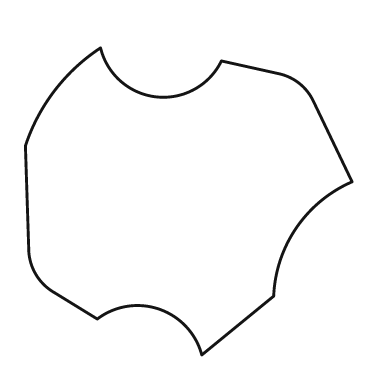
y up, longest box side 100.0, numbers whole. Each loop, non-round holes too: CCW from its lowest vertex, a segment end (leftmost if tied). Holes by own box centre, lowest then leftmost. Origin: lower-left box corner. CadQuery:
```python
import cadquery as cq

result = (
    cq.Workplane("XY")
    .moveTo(54.0, 0.0)
    .lineTo(76.0, 18.0)
    .threePointArc((83.0, 39.0), (100.0, 53.0))
    .lineTo(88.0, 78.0)
    .threePointArc((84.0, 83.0), (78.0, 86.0))
    .lineTo(60.0, 90.0)
    .threePointArc((40.0, 79.0), (23.0, 94.0))
    .threePointArc((9.0, 81.0), (0.0, 64.0))
    .lineTo(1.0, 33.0)
    .threePointArc((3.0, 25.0), (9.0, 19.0))
    .lineTo(22.0, 11.0)
    .threePointArc((41.0, 14.0), (54.0, 0.0))
    .close()
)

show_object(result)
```